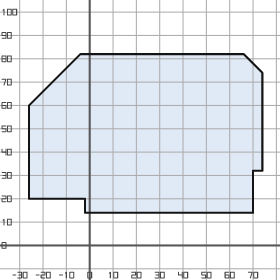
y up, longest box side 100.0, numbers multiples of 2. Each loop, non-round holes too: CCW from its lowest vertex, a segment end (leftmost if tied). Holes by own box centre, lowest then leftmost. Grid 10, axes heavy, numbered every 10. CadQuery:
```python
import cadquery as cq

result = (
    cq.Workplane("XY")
    .moveTo(-2.0, 14.0)
    .lineTo(70.0, 14.0)
    .lineTo(70.0, 32.0)
    .lineTo(74.0, 32.0)
    .lineTo(74.0, 74.0)
    .lineTo(66.0, 82.0)
    .lineTo(-4.0, 82.0)
    .lineTo(-26.0, 60.0)
    .lineTo(-26.0, 20.0)
    .lineTo(-2.0, 20.0)
    .close()
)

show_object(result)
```